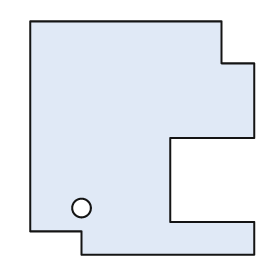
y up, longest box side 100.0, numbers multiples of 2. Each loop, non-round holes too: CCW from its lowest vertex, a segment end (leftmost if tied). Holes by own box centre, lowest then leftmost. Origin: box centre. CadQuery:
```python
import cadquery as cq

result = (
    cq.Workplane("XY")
    .moveTo(-26.0, -50.0)
    .lineTo(48.0, -50.0)
    .lineTo(48.0, -36.0)
    .lineTo(12.0, -36.0)
    .lineTo(12.0, 0.0)
    .lineTo(48.0, 0.0)
    .lineTo(48.0, 32.0)
    .lineTo(34.0, 32.0)
    .lineTo(34.0, 50.0)
    .lineTo(-48.0, 50.0)
    .lineTo(-48.0, -40.0)
    .lineTo(-26.0, -40.0)
    .close()
    .moveTo(-26.0, -30.0)
    .circle(4.0)
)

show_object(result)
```